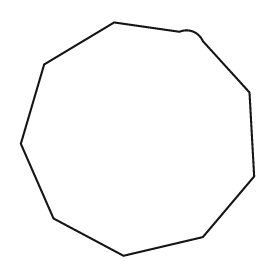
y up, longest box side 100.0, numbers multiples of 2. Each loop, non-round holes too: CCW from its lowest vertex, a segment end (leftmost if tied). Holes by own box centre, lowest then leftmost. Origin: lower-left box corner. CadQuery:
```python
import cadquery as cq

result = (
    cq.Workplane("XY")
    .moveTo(44.0, 0.0)
    .lineTo(78.0, 8.0)
    .lineTo(100.0, 34.0)
    .lineTo(98.0, 70.0)
    .lineTo(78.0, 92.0)
    .threePointArc((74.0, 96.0), (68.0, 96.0))
    .lineTo(40.0, 100.0)
    .lineTo(10.0, 82.0)
    .lineTo(0.0, 48.0)
    .lineTo(14.0, 16.0)
    .close()
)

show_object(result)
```